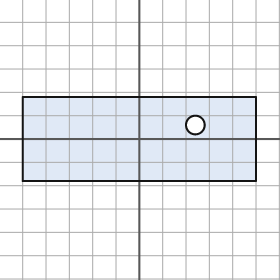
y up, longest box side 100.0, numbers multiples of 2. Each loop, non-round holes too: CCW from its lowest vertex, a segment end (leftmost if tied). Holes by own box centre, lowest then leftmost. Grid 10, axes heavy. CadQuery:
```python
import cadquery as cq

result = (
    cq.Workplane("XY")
    .moveTo(-50.0, -18.0)
    .lineTo(50.0, -18.0)
    .lineTo(50.0, 18.0)
    .lineTo(-50.0, 18.0)
    .close()
    .moveTo(24.0, 6.0)
    .circle(4.0)
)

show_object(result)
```